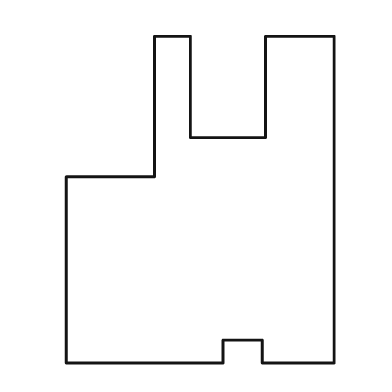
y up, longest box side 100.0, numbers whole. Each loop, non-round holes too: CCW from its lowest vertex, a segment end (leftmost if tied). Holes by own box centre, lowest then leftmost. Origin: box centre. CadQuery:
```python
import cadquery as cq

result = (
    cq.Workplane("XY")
    .moveTo(-41.0, -50.0)
    .lineTo(7.0, -50.0)
    .lineTo(7.0, -43.0)
    .lineTo(19.0, -43.0)
    .lineTo(19.0, -50.0)
    .lineTo(41.0, -50.0)
    .lineTo(41.0, 50.0)
    .lineTo(20.0, 50.0)
    .lineTo(20.0, 19.0)
    .lineTo(-3.0, 19.0)
    .lineTo(-3.0, 50.0)
    .lineTo(-14.0, 50.0)
    .lineTo(-14.0, 7.0)
    .lineTo(-41.0, 7.0)
    .close()
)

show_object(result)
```